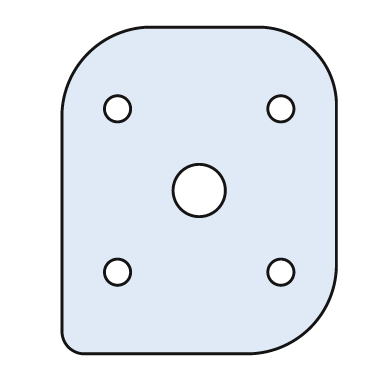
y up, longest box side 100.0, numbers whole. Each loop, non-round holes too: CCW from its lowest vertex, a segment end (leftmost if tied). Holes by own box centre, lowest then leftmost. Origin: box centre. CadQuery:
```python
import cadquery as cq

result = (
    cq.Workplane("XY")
    .moveTo(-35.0, -50.0)
    .lineTo(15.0, -50.0)
    .threePointArc((34.0, -42.0), (42.0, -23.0))
    .lineTo(42.0, 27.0)
    .threePointArc((35.0, 43.0), (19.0, 50.0))
    .lineTo(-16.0, 50.0)
    .threePointArc((-34.0, 42.0), (-42.0, 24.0))
    .lineTo(-42.0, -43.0)
    .threePointArc((-40.0, -48.0), (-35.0, -50.0))
    .close()
    .moveTo(-25.0, -25.0)
    .circle(4.0)
    .moveTo(25.0, -25.0)
    .circle(4.0)
    .moveTo(0.0, 0.0)
    .circle(8.0)
    .moveTo(-25.0, 25.0)
    .circle(4.0)
    .moveTo(25.0, 25.0)
    .circle(4.0)
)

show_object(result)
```